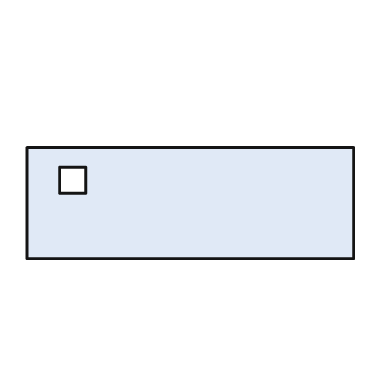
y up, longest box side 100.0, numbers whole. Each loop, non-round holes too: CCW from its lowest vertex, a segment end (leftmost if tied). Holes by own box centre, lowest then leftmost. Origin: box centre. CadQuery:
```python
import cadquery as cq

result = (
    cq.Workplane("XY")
    .moveTo(-50.0, -17.0)
    .lineTo(50.0, -17.0)
    .lineTo(50.0, 17.0)
    .lineTo(-50.0, 17.0)
    .close()
    .moveTo(-40.0, 3.0)
    .lineTo(-32.0, 3.0)
    .lineTo(-32.0, 11.0)
    .lineTo(-40.0, 11.0)
    .close()
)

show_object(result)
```